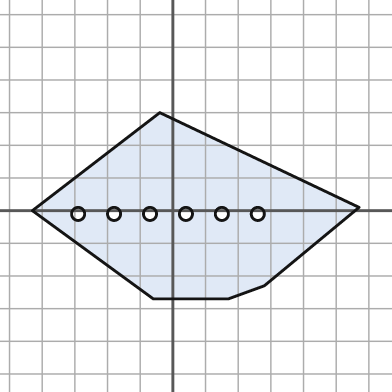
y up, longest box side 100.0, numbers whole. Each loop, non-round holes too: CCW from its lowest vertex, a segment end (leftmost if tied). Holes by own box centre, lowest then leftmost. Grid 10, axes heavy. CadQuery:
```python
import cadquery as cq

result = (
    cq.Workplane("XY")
    .moveTo(-6.0, -27.0)
    .lineTo(17.0, -27.0)
    .lineTo(28.0, -23.0)
    .lineTo(57.0, 1.0)
    .lineTo(-4.0, 30.0)
    .lineTo(-43.0, 0.0)
    .close()
    .moveTo(-29.0, -1.0)
    .circle(2.0)
    .moveTo(-18.0, -1.0)
    .circle(2.0)
    .moveTo(-7.0, -1.0)
    .circle(2.0)
    .moveTo(4.0, -1.0)
    .circle(2.0)
    .moveTo(15.0, -1.0)
    .circle(2.0)
    .moveTo(26.0, -1.0)
    .circle(2.0)
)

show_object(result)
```